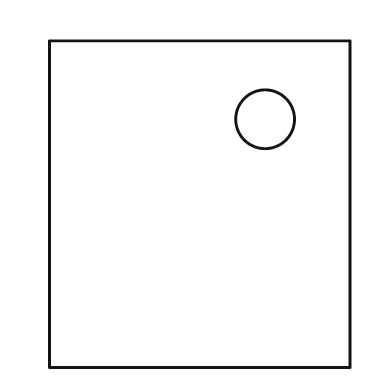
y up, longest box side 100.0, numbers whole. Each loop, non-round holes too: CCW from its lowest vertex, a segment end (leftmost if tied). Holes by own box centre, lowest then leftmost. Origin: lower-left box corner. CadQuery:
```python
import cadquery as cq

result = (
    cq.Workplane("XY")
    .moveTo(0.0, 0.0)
    .lineTo(92.0, 0.0)
    .lineTo(92.0, 100.0)
    .lineTo(0.0, 100.0)
    .close()
    .moveTo(66.0, 76.0)
    .circle(9.0)
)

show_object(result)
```